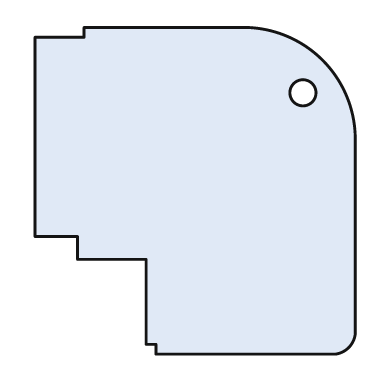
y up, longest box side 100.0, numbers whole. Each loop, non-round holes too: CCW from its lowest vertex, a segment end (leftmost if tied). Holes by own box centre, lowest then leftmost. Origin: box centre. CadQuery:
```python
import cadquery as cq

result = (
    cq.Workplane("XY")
    .moveTo(-12.0, -50.0)
    .lineTo(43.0, -50.0)
    .threePointArc((47.0, -48.0), (49.0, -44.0))
    .lineTo(49.0, 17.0)
    .threePointArc((39.0, 40.0), (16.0, 50.0))
    .lineTo(-34.0, 50.0)
    .lineTo(-34.0, 47.0)
    .lineTo(-49.0, 47.0)
    .lineTo(-49.0, -14.0)
    .lineTo(-36.0, -14.0)
    .lineTo(-36.0, -21.0)
    .lineTo(-15.0, -21.0)
    .lineTo(-15.0, -47.0)
    .lineTo(-12.0, -47.0)
    .close()
    .moveTo(33.0, 30.0)
    .circle(4.0)
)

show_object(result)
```